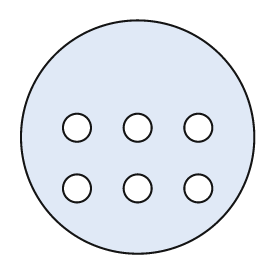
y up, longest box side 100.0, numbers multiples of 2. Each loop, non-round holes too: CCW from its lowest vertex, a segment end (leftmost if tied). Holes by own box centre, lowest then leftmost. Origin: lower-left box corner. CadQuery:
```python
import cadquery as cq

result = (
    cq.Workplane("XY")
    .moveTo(50.0, 50.0)
    .circle(50.0)
    .moveTo(24.0, 28.0)
    .circle(6.0)
    .moveTo(50.0, 28.0)
    .circle(6.0)
    .moveTo(76.0, 28.0)
    .circle(6.0)
    .moveTo(24.0, 54.0)
    .circle(6.0)
    .moveTo(50.0, 54.0)
    .circle(6.0)
    .moveTo(76.0, 54.0)
    .circle(6.0)
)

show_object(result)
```